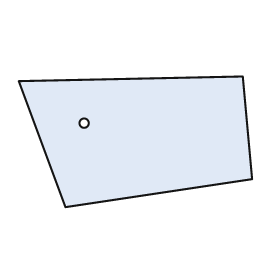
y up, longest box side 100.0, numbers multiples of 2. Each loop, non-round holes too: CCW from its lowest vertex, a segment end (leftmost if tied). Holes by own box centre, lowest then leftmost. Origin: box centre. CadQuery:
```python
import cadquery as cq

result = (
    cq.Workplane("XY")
    .moveTo(-30.0, -28.0)
    .lineTo(50.0, -16.0)
    .lineTo(46.0, 28.0)
    .lineTo(-50.0, 26.0)
    .close()
    .moveTo(-22.0, 8.0)
    .circle(2.0)
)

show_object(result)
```